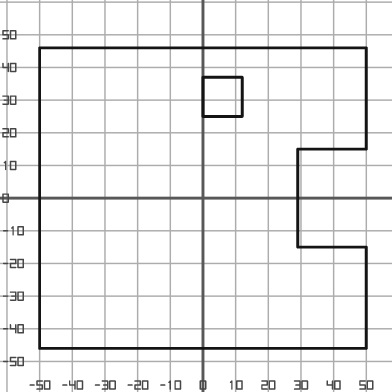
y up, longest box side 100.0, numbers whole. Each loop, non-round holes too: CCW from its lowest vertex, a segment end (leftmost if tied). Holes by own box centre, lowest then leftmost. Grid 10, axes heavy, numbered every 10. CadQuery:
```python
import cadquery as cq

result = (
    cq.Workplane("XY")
    .moveTo(-50.0, -46.0)
    .lineTo(50.0, -46.0)
    .lineTo(50.0, -15.0)
    .lineTo(29.0, -15.0)
    .lineTo(29.0, 15.0)
    .lineTo(50.0, 15.0)
    .lineTo(50.0, 46.0)
    .lineTo(-50.0, 46.0)
    .close()
    .moveTo(0.0, 25.0)
    .lineTo(12.0, 25.0)
    .lineTo(12.0, 37.0)
    .lineTo(0.0, 37.0)
    .close()
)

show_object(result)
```